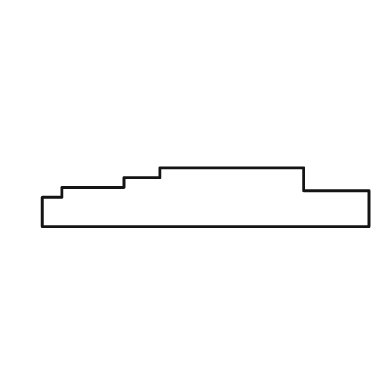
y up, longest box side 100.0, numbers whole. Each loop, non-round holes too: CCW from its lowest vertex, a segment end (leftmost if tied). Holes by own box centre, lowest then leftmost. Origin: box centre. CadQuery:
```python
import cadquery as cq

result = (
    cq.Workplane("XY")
    .moveTo(-50.0, -9.0)
    .lineTo(50.0, -9.0)
    .lineTo(50.0, 2.0)
    .lineTo(30.0, 2.0)
    .lineTo(30.0, 9.0)
    .lineTo(-14.0, 9.0)
    .lineTo(-14.0, 6.0)
    .lineTo(-25.0, 6.0)
    .lineTo(-25.0, 3.0)
    .lineTo(-44.0, 3.0)
    .lineTo(-44.0, 0.0)
    .lineTo(-50.0, 0.0)
    .close()
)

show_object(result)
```